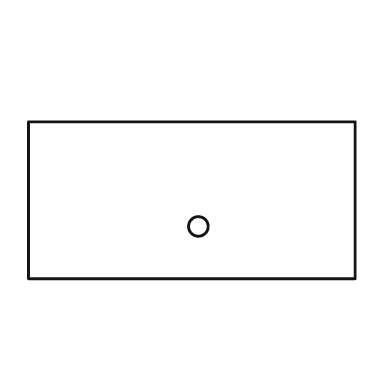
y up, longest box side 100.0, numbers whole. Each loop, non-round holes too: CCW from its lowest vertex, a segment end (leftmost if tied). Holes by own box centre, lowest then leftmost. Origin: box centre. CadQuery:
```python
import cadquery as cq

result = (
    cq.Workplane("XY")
    .moveTo(-50.0, -24.0)
    .lineTo(50.0, -24.0)
    .lineTo(50.0, 24.0)
    .lineTo(-50.0, 24.0)
    .close()
    .moveTo(2.0, -8.0)
    .circle(3.0)
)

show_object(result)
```